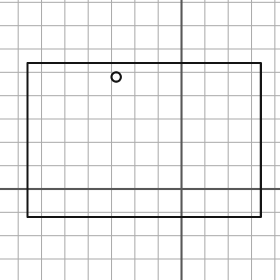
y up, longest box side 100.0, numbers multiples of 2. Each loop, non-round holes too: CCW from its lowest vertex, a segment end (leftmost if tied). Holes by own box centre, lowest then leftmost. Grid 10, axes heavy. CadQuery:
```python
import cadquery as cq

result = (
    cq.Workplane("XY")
    .moveTo(-66.0, -12.0)
    .lineTo(34.0, -12.0)
    .lineTo(34.0, 54.0)
    .lineTo(-66.0, 54.0)
    .close()
    .moveTo(-28.0, 48.0)
    .circle(2.0)
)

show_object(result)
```